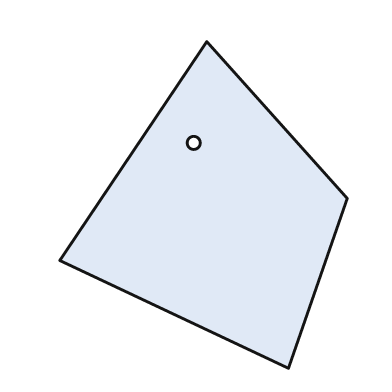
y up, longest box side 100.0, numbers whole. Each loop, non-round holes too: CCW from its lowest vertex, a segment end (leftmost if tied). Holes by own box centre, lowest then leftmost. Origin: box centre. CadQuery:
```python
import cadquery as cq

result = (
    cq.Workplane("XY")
    .moveTo(26.0, -50.0)
    .lineTo(44.0, 2.0)
    .lineTo(1.0, 50.0)
    .lineTo(-44.0, -17.0)
    .close()
    .moveTo(-3.0, 19.0)
    .circle(2.0)
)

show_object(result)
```